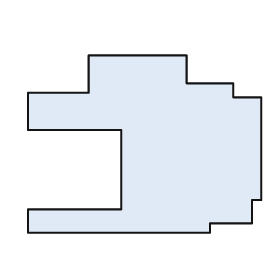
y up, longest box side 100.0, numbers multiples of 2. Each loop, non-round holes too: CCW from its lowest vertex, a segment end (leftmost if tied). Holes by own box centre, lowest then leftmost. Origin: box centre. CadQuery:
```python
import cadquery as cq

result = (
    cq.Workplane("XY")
    .moveTo(-50.0, -38.0)
    .lineTo(28.0, -38.0)
    .lineTo(28.0, -34.0)
    .lineTo(46.0, -34.0)
    .lineTo(46.0, -24.0)
    .lineTo(50.0, -24.0)
    .lineTo(50.0, 20.0)
    .lineTo(38.0, 20.0)
    .lineTo(38.0, 26.0)
    .lineTo(18.0, 26.0)
    .lineTo(18.0, 38.0)
    .lineTo(-24.0, 38.0)
    .lineTo(-24.0, 22.0)
    .lineTo(-50.0, 22.0)
    .lineTo(-50.0, 6.0)
    .lineTo(-10.0, 6.0)
    .lineTo(-10.0, -28.0)
    .lineTo(-50.0, -28.0)
    .close()
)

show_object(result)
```